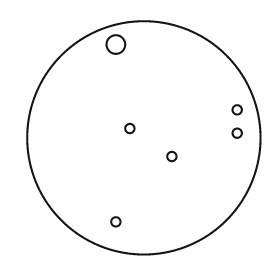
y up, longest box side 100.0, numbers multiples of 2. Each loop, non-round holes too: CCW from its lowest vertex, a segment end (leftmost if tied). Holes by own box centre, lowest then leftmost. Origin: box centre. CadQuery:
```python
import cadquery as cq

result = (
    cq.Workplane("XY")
    .moveTo(0.0, 0.0)
    .circle(50.0)
    .moveTo(-12.0, -36.0)
    .circle(2.0)
    .moveTo(12.0, -8.0)
    .circle(2.0)
    .moveTo(40.0, 2.0)
    .circle(2.0)
    .moveTo(-6.0, 4.0)
    .circle(2.0)
    .moveTo(40.0, 12.0)
    .circle(2.0)
    .moveTo(-12.0, 40.0)
    .circle(4.0)
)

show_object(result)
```